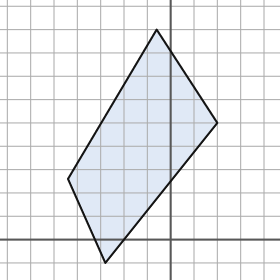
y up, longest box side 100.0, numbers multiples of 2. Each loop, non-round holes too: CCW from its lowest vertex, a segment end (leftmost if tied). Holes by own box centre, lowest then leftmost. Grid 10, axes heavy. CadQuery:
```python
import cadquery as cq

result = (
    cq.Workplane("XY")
    .moveTo(-28.0, -10.0)
    .lineTo(20.0, 50.0)
    .lineTo(-6.0, 90.0)
    .lineTo(-44.0, 26.0)
    .close()
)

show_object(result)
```